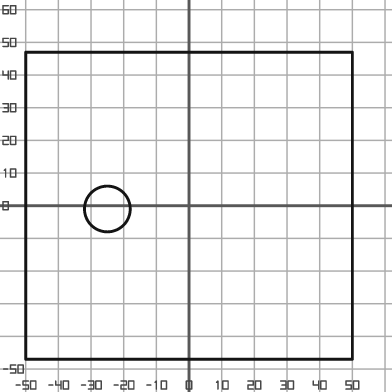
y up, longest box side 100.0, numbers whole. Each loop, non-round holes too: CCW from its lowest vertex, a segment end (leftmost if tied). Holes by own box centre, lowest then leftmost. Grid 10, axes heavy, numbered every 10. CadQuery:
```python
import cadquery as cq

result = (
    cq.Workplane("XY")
    .moveTo(-50.0, -47.0)
    .lineTo(50.0, -47.0)
    .lineTo(50.0, 47.0)
    .lineTo(-50.0, 47.0)
    .close()
    .moveTo(-25.0, -1.0)
    .circle(7.0)
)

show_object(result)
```